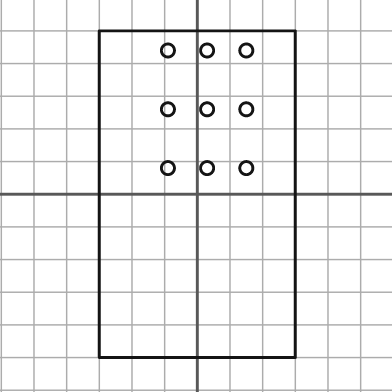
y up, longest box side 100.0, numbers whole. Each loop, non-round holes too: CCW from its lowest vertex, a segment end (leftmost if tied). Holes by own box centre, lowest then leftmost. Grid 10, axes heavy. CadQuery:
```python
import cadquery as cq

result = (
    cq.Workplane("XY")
    .moveTo(-30.0, -50.0)
    .lineTo(30.0, -50.0)
    .lineTo(30.0, 50.0)
    .lineTo(-30.0, 50.0)
    .close()
    .moveTo(-9.0, 8.0)
    .circle(2.0)
    .moveTo(3.0, 8.0)
    .circle(2.0)
    .moveTo(15.0, 8.0)
    .circle(2.0)
    .moveTo(-9.0, 26.0)
    .circle(2.0)
    .moveTo(3.0, 26.0)
    .circle(2.0)
    .moveTo(15.0, 26.0)
    .circle(2.0)
    .moveTo(-9.0, 44.0)
    .circle(2.0)
    .moveTo(3.0, 44.0)
    .circle(2.0)
    .moveTo(15.0, 44.0)
    .circle(2.0)
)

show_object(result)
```